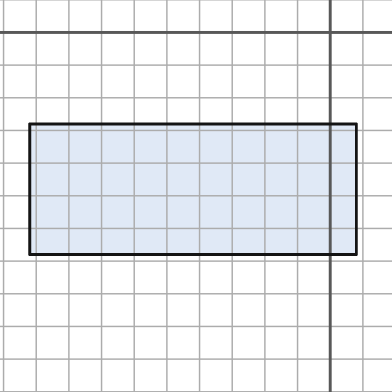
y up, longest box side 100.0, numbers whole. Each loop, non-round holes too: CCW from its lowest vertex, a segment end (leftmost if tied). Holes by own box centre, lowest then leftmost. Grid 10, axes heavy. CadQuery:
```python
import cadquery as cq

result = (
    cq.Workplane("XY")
    .moveTo(-92.0, -68.0)
    .lineTo(8.0, -68.0)
    .lineTo(8.0, -28.0)
    .lineTo(-92.0, -28.0)
    .close()
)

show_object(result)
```